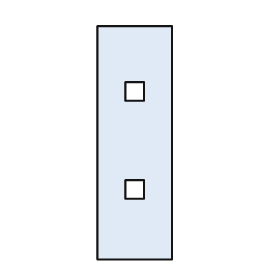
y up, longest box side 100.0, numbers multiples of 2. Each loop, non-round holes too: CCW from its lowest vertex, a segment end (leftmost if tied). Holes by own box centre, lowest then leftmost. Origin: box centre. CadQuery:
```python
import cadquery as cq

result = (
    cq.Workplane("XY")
    .moveTo(-16.0, -50.0)
    .lineTo(16.0, -50.0)
    .lineTo(16.0, 50.0)
    .lineTo(-16.0, 50.0)
    .close()
    .moveTo(-4.0, -24.0)
    .lineTo(4.0, -24.0)
    .lineTo(4.0, -16.0)
    .lineTo(-4.0, -16.0)
    .close()
    .moveTo(-4.0, 18.0)
    .lineTo(4.0, 18.0)
    .lineTo(4.0, 26.0)
    .lineTo(-4.0, 26.0)
    .close()
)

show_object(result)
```